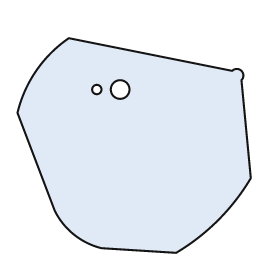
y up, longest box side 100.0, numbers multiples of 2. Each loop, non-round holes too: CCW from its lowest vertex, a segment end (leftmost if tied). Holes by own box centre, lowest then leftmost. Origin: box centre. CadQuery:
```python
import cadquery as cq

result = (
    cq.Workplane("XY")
    .moveTo(18.0, -46.0)
    .threePointArc((36.0, -32.0), (50.0, -14.0))
    .lineTo(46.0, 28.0)
    .threePointArc((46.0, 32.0), (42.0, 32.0))
    .lineTo(-28.0, 46.0)
    .threePointArc((-42.0, 32.0), (-50.0, 14.0))
    .lineTo(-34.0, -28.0)
    .threePointArc((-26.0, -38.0), (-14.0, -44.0))
    .close()
    .moveTo(-16.0, 24.0)
    .circle(2.0)
    .moveTo(-6.0, 24.0)
    .circle(4.0)
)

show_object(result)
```